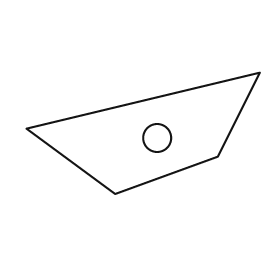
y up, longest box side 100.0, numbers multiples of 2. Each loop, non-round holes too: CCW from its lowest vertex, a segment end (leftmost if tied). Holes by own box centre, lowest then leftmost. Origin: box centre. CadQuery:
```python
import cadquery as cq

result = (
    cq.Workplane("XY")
    .moveTo(-12.0, -26.0)
    .lineTo(32.0, -10.0)
    .lineTo(50.0, 26.0)
    .lineTo(-50.0, 2.0)
    .close()
    .moveTo(6.0, -2.0)
    .circle(6.0)
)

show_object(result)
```